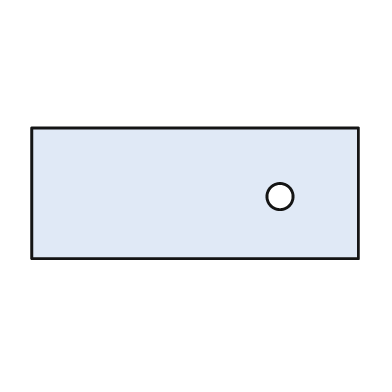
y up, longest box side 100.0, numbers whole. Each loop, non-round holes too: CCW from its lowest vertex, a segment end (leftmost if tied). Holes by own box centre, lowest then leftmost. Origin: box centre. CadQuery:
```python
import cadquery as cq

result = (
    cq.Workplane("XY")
    .moveTo(-50.0, -20.0)
    .lineTo(50.0, -20.0)
    .lineTo(50.0, 20.0)
    .lineTo(-50.0, 20.0)
    .close()
    .moveTo(26.0, -1.0)
    .circle(4.0)
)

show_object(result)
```